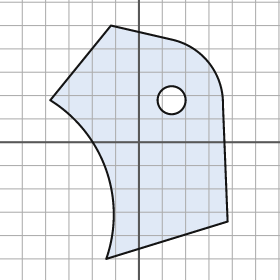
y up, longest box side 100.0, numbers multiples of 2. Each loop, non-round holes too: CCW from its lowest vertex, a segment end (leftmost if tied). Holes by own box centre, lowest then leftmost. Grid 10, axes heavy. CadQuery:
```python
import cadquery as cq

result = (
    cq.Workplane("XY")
    .moveTo(-14.0, -50.0)
    .lineTo(38.0, -34.0)
    .lineTo(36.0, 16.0)
    .threePointArc((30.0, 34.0), (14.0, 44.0))
    .lineTo(-12.0, 50.0)
    .lineTo(-38.0, 18.0)
    .threePointArc((-14.0, -12.0), (-14.0, -50.0))
    .close()
    .moveTo(14.0, 18.0)
    .circle(6.0)
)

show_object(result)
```